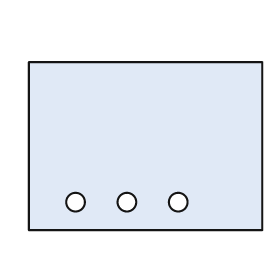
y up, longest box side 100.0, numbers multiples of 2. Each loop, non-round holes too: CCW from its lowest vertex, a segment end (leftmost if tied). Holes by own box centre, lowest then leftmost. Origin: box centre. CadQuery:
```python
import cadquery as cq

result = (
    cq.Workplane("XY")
    .moveTo(-50.0, -36.0)
    .lineTo(50.0, -36.0)
    .lineTo(50.0, 36.0)
    .lineTo(-50.0, 36.0)
    .close()
    .moveTo(-30.0, -24.0)
    .circle(4.0)
    .moveTo(-8.0, -24.0)
    .circle(4.0)
    .moveTo(14.0, -24.0)
    .circle(4.0)
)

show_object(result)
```